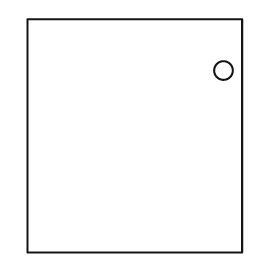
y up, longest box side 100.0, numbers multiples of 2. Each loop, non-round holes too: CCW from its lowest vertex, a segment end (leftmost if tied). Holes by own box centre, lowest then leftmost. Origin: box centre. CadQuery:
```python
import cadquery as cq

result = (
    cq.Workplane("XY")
    .moveTo(-46.0, -50.0)
    .lineTo(46.0, -50.0)
    .lineTo(46.0, 50.0)
    .lineTo(-46.0, 50.0)
    .close()
    .moveTo(38.0, 28.0)
    .circle(4.0)
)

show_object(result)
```